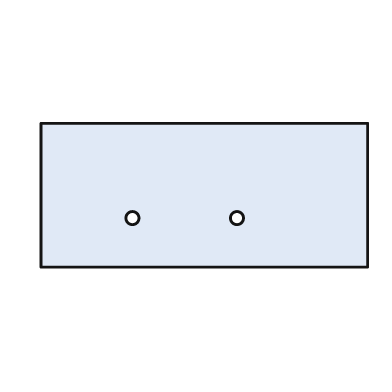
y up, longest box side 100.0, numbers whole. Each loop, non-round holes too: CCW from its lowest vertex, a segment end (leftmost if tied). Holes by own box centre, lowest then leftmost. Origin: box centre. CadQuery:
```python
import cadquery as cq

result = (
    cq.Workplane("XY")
    .moveTo(-50.0, -22.0)
    .lineTo(50.0, -22.0)
    .lineTo(50.0, 22.0)
    .lineTo(-50.0, 22.0)
    .close()
    .moveTo(-22.0, -7.0)
    .circle(2.0)
    .moveTo(10.0, -7.0)
    .circle(2.0)
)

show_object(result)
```